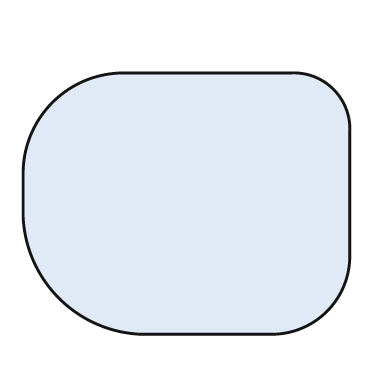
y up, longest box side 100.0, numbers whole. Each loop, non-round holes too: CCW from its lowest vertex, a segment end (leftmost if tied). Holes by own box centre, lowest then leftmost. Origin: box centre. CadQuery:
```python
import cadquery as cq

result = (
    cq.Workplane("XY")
    .moveTo(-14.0, -40.0)
    .lineTo(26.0, -40.0)
    .threePointArc((43.0, -33.0), (50.0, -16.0))
    .lineTo(50.0, 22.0)
    .threePointArc((45.0, 35.0), (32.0, 40.0))
    .lineTo(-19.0, 40.0)
    .threePointArc((-41.0, 31.0), (-50.0, 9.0))
    .lineTo(-50.0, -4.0)
    .threePointArc((-39.0, -29.0), (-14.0, -40.0))
    .close()
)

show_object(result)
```